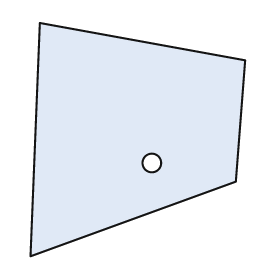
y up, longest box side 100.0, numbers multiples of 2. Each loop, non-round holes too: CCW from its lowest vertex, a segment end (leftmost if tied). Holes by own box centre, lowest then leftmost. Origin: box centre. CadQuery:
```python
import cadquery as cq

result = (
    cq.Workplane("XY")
    .moveTo(-46.0, -50.0)
    .lineTo(42.0, -18.0)
    .lineTo(46.0, 34.0)
    .lineTo(-42.0, 50.0)
    .close()
    .moveTo(6.0, -10.0)
    .circle(4.0)
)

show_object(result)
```